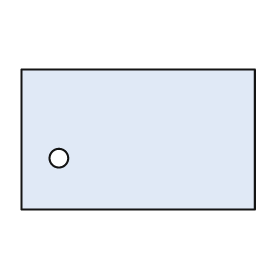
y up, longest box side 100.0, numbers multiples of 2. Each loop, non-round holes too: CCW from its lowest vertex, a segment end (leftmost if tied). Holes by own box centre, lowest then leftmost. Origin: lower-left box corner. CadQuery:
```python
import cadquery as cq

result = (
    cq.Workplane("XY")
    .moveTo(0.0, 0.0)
    .lineTo(100.0, 0.0)
    .lineTo(100.0, 60.0)
    .lineTo(0.0, 60.0)
    .close()
    .moveTo(16.0, 22.0)
    .circle(4.0)
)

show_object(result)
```